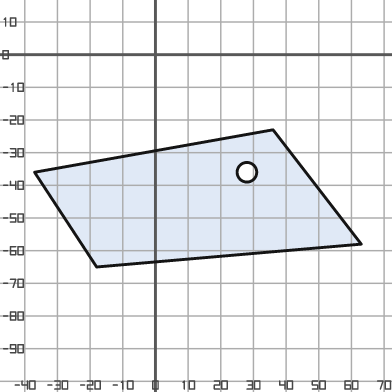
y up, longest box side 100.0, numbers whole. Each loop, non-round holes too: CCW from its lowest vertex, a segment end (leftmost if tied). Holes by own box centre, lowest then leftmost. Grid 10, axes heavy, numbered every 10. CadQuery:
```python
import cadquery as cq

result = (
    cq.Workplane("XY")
    .moveTo(-18.0, -65.0)
    .lineTo(63.0, -58.0)
    .lineTo(36.0, -23.0)
    .lineTo(-37.0, -36.0)
    .close()
    .moveTo(28.0, -36.0)
    .circle(3.0)
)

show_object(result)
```